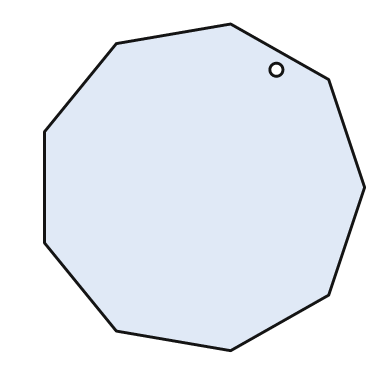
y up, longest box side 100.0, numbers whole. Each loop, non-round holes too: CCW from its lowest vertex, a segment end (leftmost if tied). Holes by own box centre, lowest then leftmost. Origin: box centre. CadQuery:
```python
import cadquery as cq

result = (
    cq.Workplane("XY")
    .moveTo(8.0, -50.0)
    .lineTo(38.0, -33.0)
    .lineTo(49.0, 0.0)
    .lineTo(38.0, 33.0)
    .lineTo(8.0, 50.0)
    .lineTo(-27.0, 44.0)
    .lineTo(-49.0, 17.0)
    .lineTo(-49.0, -17.0)
    .lineTo(-27.0, -44.0)
    .close()
    .moveTo(22.0, 36.0)
    .circle(2.0)
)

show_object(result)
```